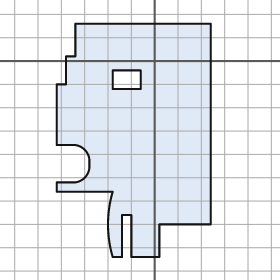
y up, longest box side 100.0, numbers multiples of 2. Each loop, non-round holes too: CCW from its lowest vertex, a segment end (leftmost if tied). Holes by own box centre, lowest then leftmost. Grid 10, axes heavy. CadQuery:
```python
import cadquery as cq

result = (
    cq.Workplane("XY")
    .moveTo(-18.0, -84.0)
    .lineTo(-14.0, -84.0)
    .lineTo(-14.0, -66.0)
    .lineTo(-10.0, -66.0)
    .lineTo(-10.0, -84.0)
    .lineTo(2.0, -84.0)
    .lineTo(2.0, -70.0)
    .lineTo(24.0, -70.0)
    .lineTo(24.0, 16.0)
    .lineTo(-34.0, 16.0)
    .lineTo(-34.0, 2.0)
    .lineTo(-38.0, 2.0)
    .lineTo(-38.0, -10.0)
    .lineTo(-42.0, -10.0)
    .lineTo(-42.0, -36.0)
    .lineTo(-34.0, -36.0)
    .threePointArc((-30.0, -38.0), (-28.0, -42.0))
    .lineTo(-28.0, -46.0)
    .threePointArc((-30.0, -50.0), (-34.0, -52.0))
    .lineTo(-42.0, -52.0)
    .lineTo(-42.0, -56.0)
    .lineTo(-18.0, -56.0)
    .threePointArc((-20.0, -70.0), (-18.0, -84.0))
    .close()
    .moveTo(-18.0, -12.0)
    .lineTo(-6.0, -12.0)
    .lineTo(-6.0, -4.0)
    .lineTo(-18.0, -4.0)
    .close()
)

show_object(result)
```